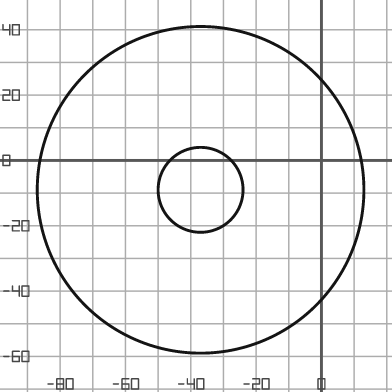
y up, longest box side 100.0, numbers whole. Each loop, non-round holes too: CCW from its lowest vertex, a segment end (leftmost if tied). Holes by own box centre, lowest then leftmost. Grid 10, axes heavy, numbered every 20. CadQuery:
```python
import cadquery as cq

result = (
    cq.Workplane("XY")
    .moveTo(-37.0, -9.0)
    .circle(50.0)
    .moveTo(-37.0, -9.0)
    .circle(13.0)
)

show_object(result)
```